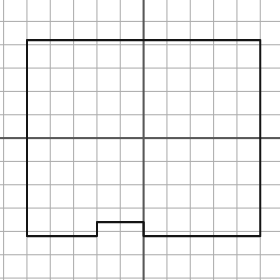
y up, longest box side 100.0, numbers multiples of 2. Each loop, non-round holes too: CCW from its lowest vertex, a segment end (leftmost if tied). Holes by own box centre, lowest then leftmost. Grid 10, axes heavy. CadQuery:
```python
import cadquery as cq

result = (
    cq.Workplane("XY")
    .moveTo(-50.0, -42.0)
    .lineTo(-20.0, -42.0)
    .lineTo(-20.0, -36.0)
    .lineTo(0.0, -36.0)
    .lineTo(0.0, -42.0)
    .lineTo(50.0, -42.0)
    .lineTo(50.0, 42.0)
    .lineTo(-50.0, 42.0)
    .close()
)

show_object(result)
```